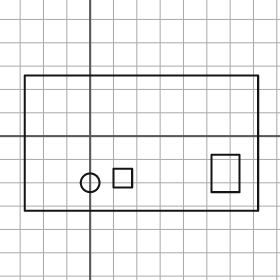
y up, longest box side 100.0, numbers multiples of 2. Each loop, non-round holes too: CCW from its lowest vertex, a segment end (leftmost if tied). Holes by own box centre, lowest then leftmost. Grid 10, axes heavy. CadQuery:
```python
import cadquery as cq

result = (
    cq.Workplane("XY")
    .moveTo(-28.0, -32.0)
    .lineTo(72.0, -32.0)
    .lineTo(72.0, 26.0)
    .lineTo(-28.0, 26.0)
    .close()
    .moveTo(0.0, -20.0)
    .circle(4.0)
    .moveTo(10.0, -22.0)
    .lineTo(18.0, -22.0)
    .lineTo(18.0, -14.0)
    .lineTo(10.0, -14.0)
    .close()
    .moveTo(52.0, -24.0)
    .lineTo(64.0, -24.0)
    .lineTo(64.0, -8.0)
    .lineTo(52.0, -8.0)
    .close()
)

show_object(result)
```